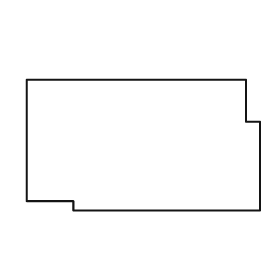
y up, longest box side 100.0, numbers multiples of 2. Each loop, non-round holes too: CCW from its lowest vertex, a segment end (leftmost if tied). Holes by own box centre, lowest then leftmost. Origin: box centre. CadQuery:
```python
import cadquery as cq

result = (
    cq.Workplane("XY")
    .moveTo(-30.0, -28.0)
    .lineTo(50.0, -28.0)
    .lineTo(50.0, 10.0)
    .lineTo(44.0, 10.0)
    .lineTo(44.0, 28.0)
    .lineTo(-50.0, 28.0)
    .lineTo(-50.0, -24.0)
    .lineTo(-30.0, -24.0)
    .close()
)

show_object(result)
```